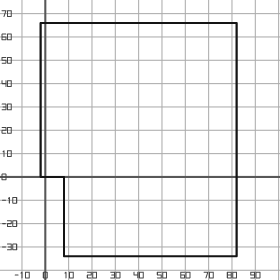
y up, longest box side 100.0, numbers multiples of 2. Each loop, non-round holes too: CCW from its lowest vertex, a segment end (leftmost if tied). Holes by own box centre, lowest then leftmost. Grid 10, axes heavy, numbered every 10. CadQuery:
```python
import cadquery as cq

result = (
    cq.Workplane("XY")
    .moveTo(8.0, -34.0)
    .lineTo(82.0, -34.0)
    .lineTo(82.0, 66.0)
    .lineTo(-2.0, 66.0)
    .lineTo(-2.0, 0.0)
    .lineTo(8.0, 0.0)
    .close()
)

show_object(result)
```